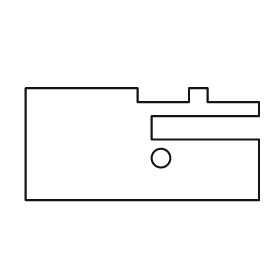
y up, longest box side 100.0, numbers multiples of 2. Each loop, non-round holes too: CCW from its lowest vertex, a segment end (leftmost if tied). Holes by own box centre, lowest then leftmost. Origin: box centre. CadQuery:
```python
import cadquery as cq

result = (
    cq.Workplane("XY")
    .moveTo(-50.0, -24.0)
    .lineTo(50.0, -24.0)
    .lineTo(50.0, 2.0)
    .lineTo(4.0, 2.0)
    .lineTo(4.0, 12.0)
    .lineTo(50.0, 12.0)
    .lineTo(50.0, 18.0)
    .lineTo(28.0, 18.0)
    .lineTo(28.0, 24.0)
    .lineTo(20.0, 24.0)
    .lineTo(20.0, 18.0)
    .lineTo(-2.0, 18.0)
    .lineTo(-2.0, 24.0)
    .lineTo(-50.0, 24.0)
    .close()
    .moveTo(8.0, -6.0)
    .circle(4.0)
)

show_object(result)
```